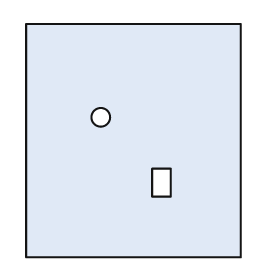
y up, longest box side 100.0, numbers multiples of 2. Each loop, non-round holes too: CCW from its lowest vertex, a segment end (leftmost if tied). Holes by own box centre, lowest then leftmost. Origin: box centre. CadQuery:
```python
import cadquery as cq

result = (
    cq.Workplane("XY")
    .moveTo(-46.0, -50.0)
    .lineTo(46.0, -50.0)
    .lineTo(46.0, 50.0)
    .lineTo(-46.0, 50.0)
    .close()
    .moveTo(8.0, -24.0)
    .lineTo(16.0, -24.0)
    .lineTo(16.0, -12.0)
    .lineTo(8.0, -12.0)
    .close()
    .moveTo(-14.0, 10.0)
    .circle(4.0)
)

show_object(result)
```